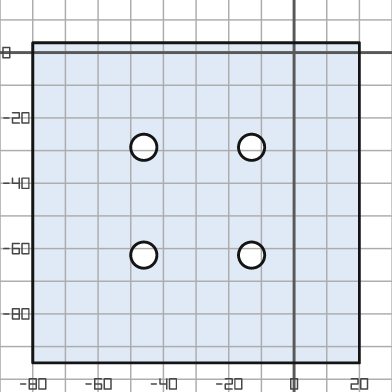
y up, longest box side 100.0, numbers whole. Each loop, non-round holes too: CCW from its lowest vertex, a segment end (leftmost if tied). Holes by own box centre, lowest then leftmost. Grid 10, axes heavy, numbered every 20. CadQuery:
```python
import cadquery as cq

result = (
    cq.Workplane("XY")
    .moveTo(-80.0, -95.0)
    .lineTo(20.0, -95.0)
    .lineTo(20.0, 3.0)
    .lineTo(-80.0, 3.0)
    .close()
    .moveTo(-46.0, -62.0)
    .circle(4.0)
    .moveTo(-13.0, -62.0)
    .circle(4.0)
    .moveTo(-46.0, -29.0)
    .circle(4.0)
    .moveTo(-13.0, -29.0)
    .circle(4.0)
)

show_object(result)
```